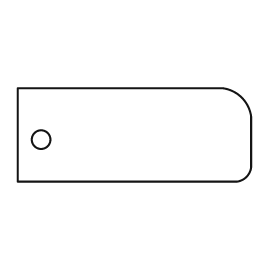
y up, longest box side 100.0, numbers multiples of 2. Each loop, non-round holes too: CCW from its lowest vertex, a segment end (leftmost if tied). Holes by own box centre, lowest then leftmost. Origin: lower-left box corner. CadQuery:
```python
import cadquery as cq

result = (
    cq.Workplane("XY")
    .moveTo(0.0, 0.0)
    .lineTo(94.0, 0.0)
    .threePointArc((98.0, 2.0), (100.0, 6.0))
    .lineTo(100.0, 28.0)
    .threePointArc((96.0, 36.0), (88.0, 40.0))
    .lineTo(0.0, 40.0)
    .close()
    .moveTo(10.0, 18.0)
    .circle(4.0)
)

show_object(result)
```